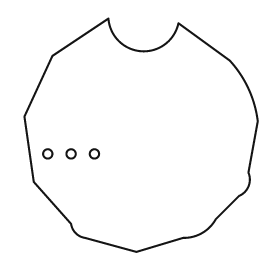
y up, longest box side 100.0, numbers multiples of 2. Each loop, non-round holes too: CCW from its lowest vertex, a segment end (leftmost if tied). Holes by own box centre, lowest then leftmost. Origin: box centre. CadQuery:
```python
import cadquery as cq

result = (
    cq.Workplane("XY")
    .moveTo(-2.0, -50.0)
    .lineTo(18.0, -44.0)
    .threePointArc((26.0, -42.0), (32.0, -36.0))
    .lineTo(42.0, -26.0)
    .threePointArc((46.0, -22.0), (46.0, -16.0))
    .lineTo(50.0, 6.0)
    .threePointArc((46.0, 20.0), (38.0, 32.0))
    .lineTo(16.0, 48.0)
    .threePointArc((0.0, 36.0), (-14.0, 50.0))
    .lineTo(-38.0, 34.0)
    .lineTo(-50.0, 8.0)
    .lineTo(-46.0, -20.0)
    .lineTo(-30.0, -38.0)
    .threePointArc((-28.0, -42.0), (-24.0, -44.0))
    .close()
    .moveTo(-40.0, -8.0)
    .circle(2.0)
    .moveTo(-30.0, -8.0)
    .circle(2.0)
    .moveTo(-20.0, -8.0)
    .circle(2.0)
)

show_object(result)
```